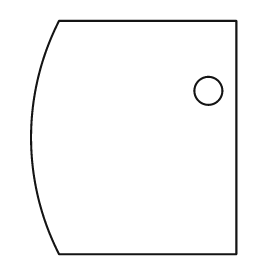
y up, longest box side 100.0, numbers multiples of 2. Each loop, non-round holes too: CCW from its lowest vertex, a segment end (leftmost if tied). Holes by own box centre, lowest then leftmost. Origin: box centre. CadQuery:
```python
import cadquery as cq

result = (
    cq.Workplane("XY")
    .moveTo(-32.0, -50.0)
    .lineTo(44.0, -50.0)
    .lineTo(44.0, 50.0)
    .lineTo(-32.0, 50.0)
    .threePointArc((-44.0, 0.0), (-32.0, -50.0))
    .close()
    .moveTo(32.0, 20.0)
    .circle(6.0)
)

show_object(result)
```